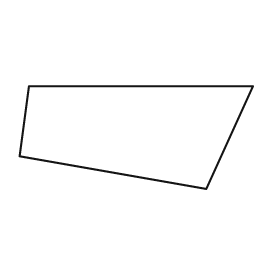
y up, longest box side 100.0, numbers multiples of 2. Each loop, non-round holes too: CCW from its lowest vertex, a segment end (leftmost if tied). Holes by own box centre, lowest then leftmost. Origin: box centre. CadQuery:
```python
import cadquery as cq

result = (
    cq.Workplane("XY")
    .moveTo(30.0, -22.0)
    .lineTo(50.0, 22.0)
    .lineTo(-46.0, 22.0)
    .lineTo(-50.0, -8.0)
    .close()
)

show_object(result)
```